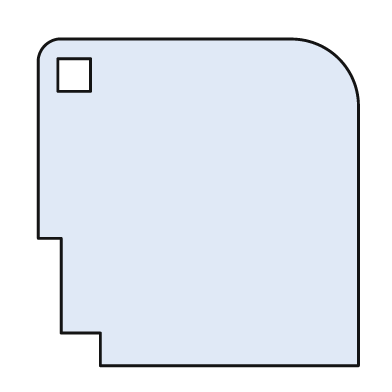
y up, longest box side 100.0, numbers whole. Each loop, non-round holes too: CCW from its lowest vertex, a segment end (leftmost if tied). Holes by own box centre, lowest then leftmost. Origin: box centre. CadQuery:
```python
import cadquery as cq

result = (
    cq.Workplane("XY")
    .moveTo(-30.0, -50.0)
    .lineTo(49.0, -50.0)
    .lineTo(49.0, 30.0)
    .threePointArc((43.0, 44.0), (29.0, 50.0))
    .lineTo(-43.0, 50.0)
    .threePointArc((-47.0, 48.0), (-49.0, 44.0))
    .lineTo(-49.0, -11.0)
    .lineTo(-42.0, -11.0)
    .lineTo(-42.0, -40.0)
    .lineTo(-30.0, -40.0)
    .close()
    .moveTo(-43.0, 34.0)
    .lineTo(-33.0, 34.0)
    .lineTo(-33.0, 44.0)
    .lineTo(-43.0, 44.0)
    .close()
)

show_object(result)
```